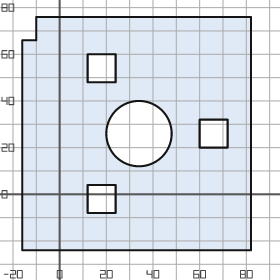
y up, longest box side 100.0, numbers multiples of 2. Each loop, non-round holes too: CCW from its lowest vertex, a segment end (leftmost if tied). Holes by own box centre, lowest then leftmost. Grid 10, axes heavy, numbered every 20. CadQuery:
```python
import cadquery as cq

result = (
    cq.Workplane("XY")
    .moveTo(-16.0, -24.0)
    .lineTo(82.0, -24.0)
    .lineTo(82.0, 76.0)
    .lineTo(-10.0, 76.0)
    .lineTo(-10.0, 66.0)
    .lineTo(-16.0, 66.0)
    .close()
    .moveTo(12.0, -8.0)
    .lineTo(24.0, -8.0)
    .lineTo(24.0, 4.0)
    .lineTo(12.0, 4.0)
    .close()
    .moveTo(34.0, 26.0)
    .circle(14.0)
    .moveTo(60.0, 20.0)
    .lineTo(72.0, 20.0)
    .lineTo(72.0, 32.0)
    .lineTo(60.0, 32.0)
    .close()
    .moveTo(12.0, 48.0)
    .lineTo(24.0, 48.0)
    .lineTo(24.0, 60.0)
    .lineTo(12.0, 60.0)
    .close()
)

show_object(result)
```